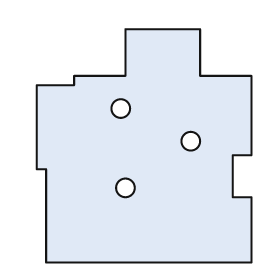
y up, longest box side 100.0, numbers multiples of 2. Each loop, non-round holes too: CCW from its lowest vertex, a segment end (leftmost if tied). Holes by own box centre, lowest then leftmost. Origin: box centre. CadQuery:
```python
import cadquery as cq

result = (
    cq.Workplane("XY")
    .moveTo(-42.0, -50.0)
    .lineTo(46.0, -50.0)
    .lineTo(46.0, -22.0)
    .lineTo(38.0, -22.0)
    .lineTo(38.0, -4.0)
    .lineTo(46.0, -4.0)
    .lineTo(46.0, 30.0)
    .lineTo(24.0, 30.0)
    .lineTo(24.0, 50.0)
    .lineTo(-8.0, 50.0)
    .lineTo(-8.0, 30.0)
    .lineTo(-30.0, 30.0)
    .lineTo(-30.0, 26.0)
    .lineTo(-46.0, 26.0)
    .lineTo(-46.0, -10.0)
    .lineTo(-42.0, -10.0)
    .close()
    .moveTo(-8.0, -18.0)
    .circle(4.0)
    .moveTo(20.0, 2.0)
    .circle(4.0)
    .moveTo(-10.0, 16.0)
    .circle(4.0)
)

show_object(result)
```